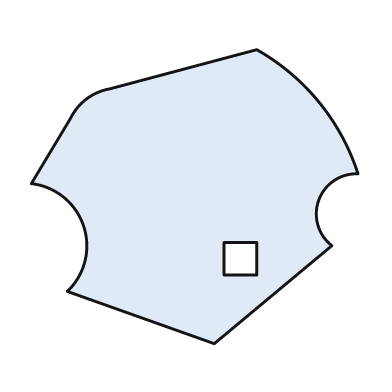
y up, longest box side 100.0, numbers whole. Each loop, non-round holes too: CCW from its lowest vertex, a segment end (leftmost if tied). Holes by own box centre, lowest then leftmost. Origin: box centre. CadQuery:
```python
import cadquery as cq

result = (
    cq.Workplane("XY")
    .moveTo(6.0, -45.0)
    .lineTo(42.0, -15.0)
    .threePointArc((38.0, -1.0), (50.0, 7.0))
    .threePointArc((38.0, 29.0), (19.0, 45.0))
    .lineTo(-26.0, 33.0)
    .threePointArc((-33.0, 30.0), (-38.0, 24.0))
    .lineTo(-50.0, 4.0)
    .threePointArc((-34.0, -9.0), (-39.0, -29.0))
    .close()
    .moveTo(9.0, -24.0)
    .lineTo(19.0, -24.0)
    .lineTo(19.0, -14.0)
    .lineTo(9.0, -14.0)
    .close()
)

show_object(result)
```